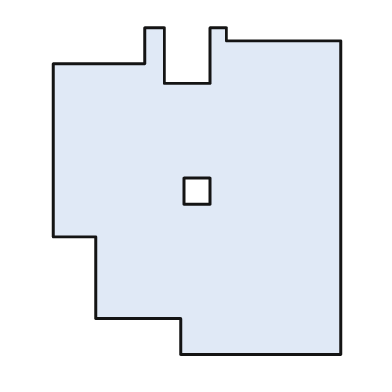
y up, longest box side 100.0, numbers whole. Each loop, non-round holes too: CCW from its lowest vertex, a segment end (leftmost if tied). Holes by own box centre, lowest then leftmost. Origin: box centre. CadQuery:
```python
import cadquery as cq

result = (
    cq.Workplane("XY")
    .moveTo(-5.0, -50.0)
    .lineTo(44.0, -50.0)
    .lineTo(44.0, 46.0)
    .lineTo(9.0, 46.0)
    .lineTo(9.0, 50.0)
    .lineTo(4.0, 50.0)
    .lineTo(4.0, 33.0)
    .lineTo(-10.0, 33.0)
    .lineTo(-10.0, 50.0)
    .lineTo(-16.0, 50.0)
    .lineTo(-16.0, 39.0)
    .lineTo(-44.0, 39.0)
    .lineTo(-44.0, -14.0)
    .lineTo(-31.0, -14.0)
    .lineTo(-31.0, -39.0)
    .lineTo(-5.0, -39.0)
    .close()
    .moveTo(-4.0, -4.0)
    .lineTo(4.0, -4.0)
    .lineTo(4.0, 4.0)
    .lineTo(-4.0, 4.0)
    .close()
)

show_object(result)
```